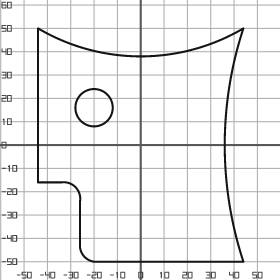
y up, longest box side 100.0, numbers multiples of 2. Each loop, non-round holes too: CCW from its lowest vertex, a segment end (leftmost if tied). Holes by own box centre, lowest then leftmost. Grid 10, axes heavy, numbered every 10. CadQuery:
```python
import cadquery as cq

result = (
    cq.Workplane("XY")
    .moveTo(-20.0, -50.0)
    .lineTo(44.0, -50.0)
    .threePointArc((36.0, 0.0), (44.0, 50.0))
    .threePointArc((0.0, 38.0), (-44.0, 50.0))
    .lineTo(-44.0, -16.0)
    .lineTo(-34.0, -16.0)
    .threePointArc((-28.0, -18.0), (-26.0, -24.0))
    .lineTo(-26.0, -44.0)
    .threePointArc((-24.0, -48.0), (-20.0, -50.0))
    .close()
    .moveTo(-20.0, 16.0)
    .circle(8.0)
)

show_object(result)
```